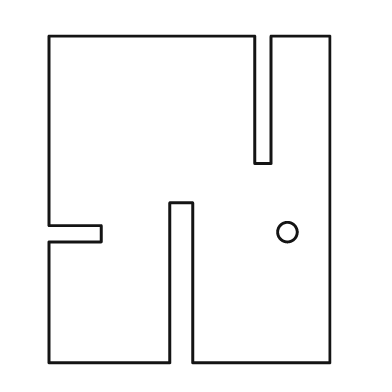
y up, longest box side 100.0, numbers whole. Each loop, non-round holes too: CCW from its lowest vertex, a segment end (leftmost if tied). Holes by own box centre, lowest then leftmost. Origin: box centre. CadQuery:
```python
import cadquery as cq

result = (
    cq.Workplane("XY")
    .moveTo(-43.0, -50.0)
    .lineTo(-6.0, -50.0)
    .lineTo(-6.0, -1.0)
    .lineTo(1.0, -1.0)
    .lineTo(1.0, -50.0)
    .lineTo(43.0, -50.0)
    .lineTo(43.0, 50.0)
    .lineTo(25.0, 50.0)
    .lineTo(25.0, 11.0)
    .lineTo(20.0, 11.0)
    .lineTo(20.0, 50.0)
    .lineTo(-43.0, 50.0)
    .lineTo(-43.0, -8.0)
    .lineTo(-27.0, -8.0)
    .lineTo(-27.0, -13.0)
    .lineTo(-43.0, -13.0)
    .close()
    .moveTo(30.0, -10.0)
    .circle(3.0)
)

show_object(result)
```